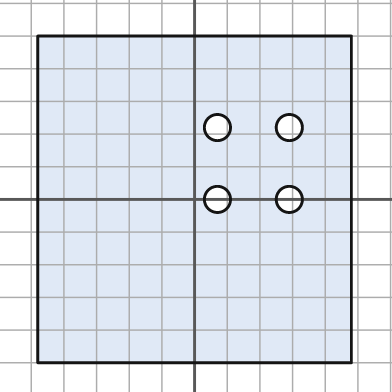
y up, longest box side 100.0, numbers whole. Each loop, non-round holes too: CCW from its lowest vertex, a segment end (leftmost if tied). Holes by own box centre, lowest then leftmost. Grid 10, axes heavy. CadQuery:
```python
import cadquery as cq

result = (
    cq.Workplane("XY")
    .moveTo(-48.0, -50.0)
    .lineTo(48.0, -50.0)
    .lineTo(48.0, 50.0)
    .lineTo(-48.0, 50.0)
    .close()
    .moveTo(7.0, 0.0)
    .circle(4.0)
    .moveTo(29.0, 0.0)
    .circle(4.0)
    .moveTo(7.0, 22.0)
    .circle(4.0)
    .moveTo(29.0, 22.0)
    .circle(4.0)
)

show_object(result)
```